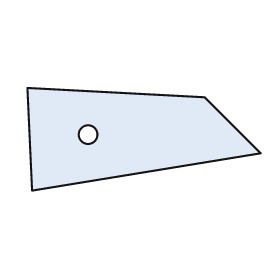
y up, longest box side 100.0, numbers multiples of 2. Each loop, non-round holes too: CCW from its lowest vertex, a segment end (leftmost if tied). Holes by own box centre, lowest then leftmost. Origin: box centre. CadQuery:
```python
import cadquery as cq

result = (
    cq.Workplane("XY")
    .moveTo(-48.0, -22.0)
    .lineTo(50.0, -6.0)
    .lineTo(26.0, 18.0)
    .lineTo(-50.0, 22.0)
    .close()
    .moveTo(-24.0, 2.0)
    .circle(4.0)
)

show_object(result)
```